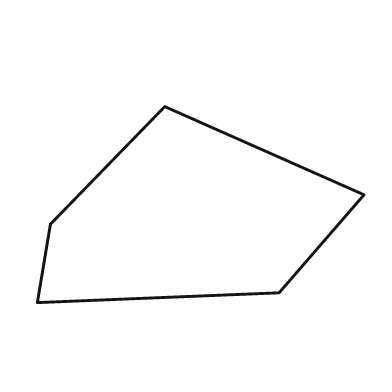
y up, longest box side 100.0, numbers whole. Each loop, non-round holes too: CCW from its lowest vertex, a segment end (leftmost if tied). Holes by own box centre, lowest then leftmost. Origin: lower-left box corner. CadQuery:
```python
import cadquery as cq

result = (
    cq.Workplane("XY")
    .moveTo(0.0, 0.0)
    .lineTo(74.0, 3.0)
    .lineTo(100.0, 33.0)
    .lineTo(39.0, 60.0)
    .lineTo(4.0, 24.0)
    .close()
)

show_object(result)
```